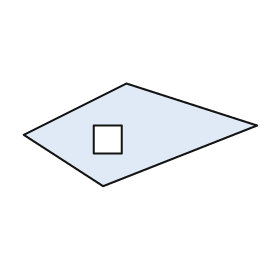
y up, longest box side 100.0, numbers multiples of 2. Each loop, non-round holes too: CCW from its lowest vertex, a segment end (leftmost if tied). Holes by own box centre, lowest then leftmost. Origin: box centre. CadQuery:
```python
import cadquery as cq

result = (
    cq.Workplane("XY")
    .moveTo(-16.0, -22.0)
    .lineTo(50.0, 4.0)
    .lineTo(-6.0, 22.0)
    .lineTo(-50.0, 0.0)
    .close()
    .moveTo(-20.0, -8.0)
    .lineTo(-8.0, -8.0)
    .lineTo(-8.0, 4.0)
    .lineTo(-20.0, 4.0)
    .close()
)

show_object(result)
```